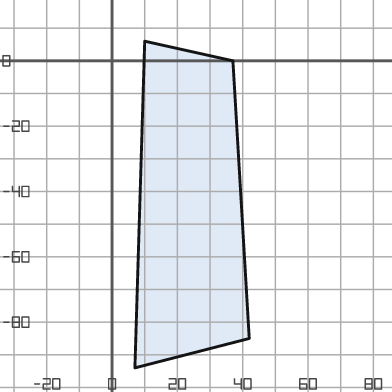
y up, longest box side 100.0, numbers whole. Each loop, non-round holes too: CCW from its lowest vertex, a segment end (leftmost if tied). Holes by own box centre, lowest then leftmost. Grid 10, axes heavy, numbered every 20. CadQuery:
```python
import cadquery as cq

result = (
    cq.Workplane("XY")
    .moveTo(7.0, -94.0)
    .lineTo(42.0, -85.0)
    .lineTo(37.0, 0.0)
    .lineTo(10.0, 6.0)
    .close()
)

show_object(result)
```